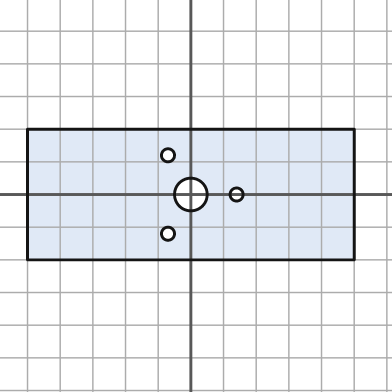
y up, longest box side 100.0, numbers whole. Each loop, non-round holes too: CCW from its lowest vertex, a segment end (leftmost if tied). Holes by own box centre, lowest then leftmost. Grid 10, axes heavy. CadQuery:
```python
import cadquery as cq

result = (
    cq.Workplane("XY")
    .moveTo(-50.0, -20.0)
    .lineTo(50.0, -20.0)
    .lineTo(50.0, 20.0)
    .lineTo(-50.0, 20.0)
    .close()
    .moveTo(-7.0, -12.0)
    .circle(2.0)
    .moveTo(0.0, 0.0)
    .circle(5.0)
    .moveTo(14.0, 0.0)
    .circle(2.0)
    .moveTo(-7.0, 12.0)
    .circle(2.0)
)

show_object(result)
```